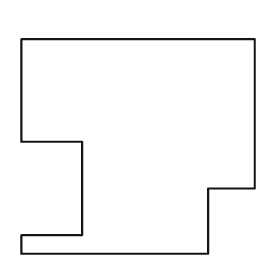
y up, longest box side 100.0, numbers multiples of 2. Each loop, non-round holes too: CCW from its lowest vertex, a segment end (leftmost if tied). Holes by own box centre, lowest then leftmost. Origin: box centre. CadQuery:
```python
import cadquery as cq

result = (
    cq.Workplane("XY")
    .moveTo(-50.0, -46.0)
    .lineTo(30.0, -46.0)
    .lineTo(30.0, -18.0)
    .lineTo(50.0, -18.0)
    .lineTo(50.0, 46.0)
    .lineTo(-50.0, 46.0)
    .lineTo(-50.0, 2.0)
    .lineTo(-24.0, 2.0)
    .lineTo(-24.0, -38.0)
    .lineTo(-50.0, -38.0)
    .close()
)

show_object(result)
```